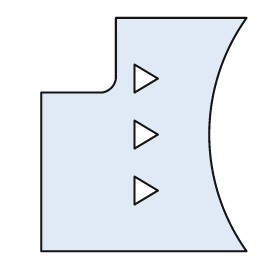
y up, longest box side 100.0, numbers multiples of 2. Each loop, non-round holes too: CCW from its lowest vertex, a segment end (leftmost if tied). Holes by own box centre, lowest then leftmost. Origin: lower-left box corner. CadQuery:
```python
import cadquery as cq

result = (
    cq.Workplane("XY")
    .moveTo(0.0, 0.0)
    .lineTo(88.0, 0.0)
    .threePointArc((72.0, 50.0), (88.0, 100.0))
    .lineTo(32.0, 100.0)
    .lineTo(32.0, 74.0)
    .threePointArc((30.0, 70.0), (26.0, 68.0))
    .lineTo(0.0, 68.0)
    .close()
    .moveTo(40.0, 20.0)
    .lineTo(50.0, 26.0)
    .lineTo(40.0, 32.0)
    .close()
    .moveTo(40.0, 44.0)
    .lineTo(50.0, 50.0)
    .lineTo(40.0, 56.0)
    .close()
    .moveTo(40.0, 68.0)
    .lineTo(50.0, 74.0)
    .lineTo(40.0, 80.0)
    .close()
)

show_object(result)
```